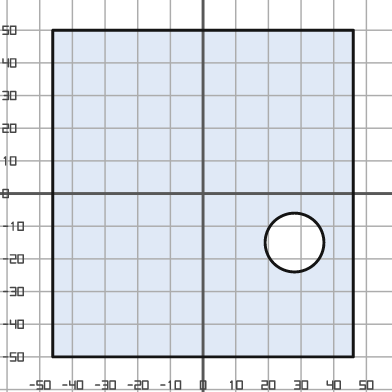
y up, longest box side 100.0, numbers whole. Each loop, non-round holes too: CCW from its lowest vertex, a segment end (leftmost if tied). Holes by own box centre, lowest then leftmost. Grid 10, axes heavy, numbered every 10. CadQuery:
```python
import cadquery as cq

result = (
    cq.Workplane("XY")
    .moveTo(-46.0, -50.0)
    .lineTo(46.0, -50.0)
    .lineTo(46.0, 50.0)
    .lineTo(-46.0, 50.0)
    .close()
    .moveTo(28.0, -15.0)
    .circle(9.0)
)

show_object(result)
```